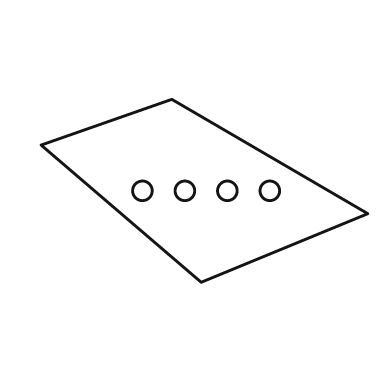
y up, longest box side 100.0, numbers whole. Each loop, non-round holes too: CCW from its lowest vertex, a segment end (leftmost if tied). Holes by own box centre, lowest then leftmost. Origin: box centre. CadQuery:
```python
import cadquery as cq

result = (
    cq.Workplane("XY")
    .moveTo(-1.0, -28.0)
    .lineTo(50.0, -7.0)
    .lineTo(-10.0, 28.0)
    .lineTo(-50.0, 14.0)
    .close()
    .moveTo(-19.0, 0.0)
    .circle(3.0)
    .moveTo(-6.0, 0.0)
    .circle(3.0)
    .moveTo(7.0, 0.0)
    .circle(3.0)
    .moveTo(20.0, 0.0)
    .circle(3.0)
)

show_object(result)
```